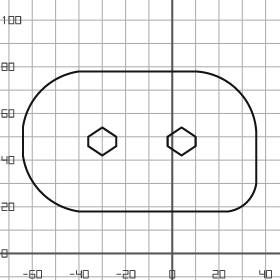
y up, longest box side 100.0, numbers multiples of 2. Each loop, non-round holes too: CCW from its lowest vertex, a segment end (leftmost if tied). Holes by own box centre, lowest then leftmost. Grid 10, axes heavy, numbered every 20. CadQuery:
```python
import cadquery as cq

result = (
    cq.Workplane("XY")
    .moveTo(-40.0, 18.0)
    .lineTo(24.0, 18.0)
    .threePointArc((32.0, 22.0), (36.0, 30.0))
    .lineTo(36.0, 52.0)
    .threePointArc((28.0, 70.0), (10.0, 78.0))
    .lineTo(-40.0, 78.0)
    .threePointArc((-56.0, 70.0), (-64.0, 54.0))
    .lineTo(-64.0, 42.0)
    .threePointArc((-56.0, 26.0), (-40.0, 18.0))
    .close()
    .moveTo(-30.0, 42.0)
    .lineTo(-24.0, 46.0)
    .lineTo(-24.0, 50.0)
    .lineTo(-30.0, 54.0)
    .lineTo(-36.0, 50.0)
    .lineTo(-36.0, 46.0)
    .close()
    .moveTo(4.0, 42.0)
    .lineTo(10.0, 46.0)
    .lineTo(10.0, 50.0)
    .lineTo(4.0, 54.0)
    .lineTo(-2.0, 50.0)
    .lineTo(-2.0, 46.0)
    .close()
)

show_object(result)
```